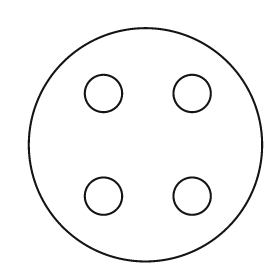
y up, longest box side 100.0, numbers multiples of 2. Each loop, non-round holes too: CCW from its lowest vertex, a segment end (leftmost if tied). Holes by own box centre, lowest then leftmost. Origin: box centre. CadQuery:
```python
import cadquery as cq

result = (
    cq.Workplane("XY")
    .moveTo(0.0, 0.0)
    .circle(50.0)
    .moveTo(-18.0, -22.0)
    .circle(8.0)
    .moveTo(20.0, -22.0)
    .circle(8.0)
    .moveTo(-18.0, 22.0)
    .circle(8.0)
    .moveTo(20.0, 22.0)
    .circle(8.0)
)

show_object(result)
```